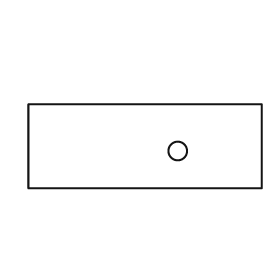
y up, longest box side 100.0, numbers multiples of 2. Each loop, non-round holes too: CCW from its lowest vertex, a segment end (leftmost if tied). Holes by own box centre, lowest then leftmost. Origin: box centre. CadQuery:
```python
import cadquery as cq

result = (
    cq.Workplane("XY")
    .moveTo(-50.0, -18.0)
    .lineTo(50.0, -18.0)
    .lineTo(50.0, 18.0)
    .lineTo(-50.0, 18.0)
    .close()
    .moveTo(14.0, -2.0)
    .circle(4.0)
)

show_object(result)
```